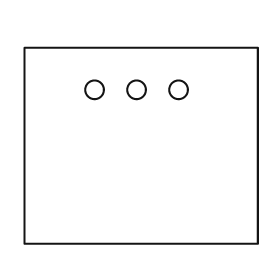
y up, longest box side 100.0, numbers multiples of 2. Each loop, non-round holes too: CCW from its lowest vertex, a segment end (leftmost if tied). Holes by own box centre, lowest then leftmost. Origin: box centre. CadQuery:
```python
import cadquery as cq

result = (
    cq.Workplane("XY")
    .moveTo(-50.0, -42.0)
    .lineTo(50.0, -42.0)
    .lineTo(50.0, 42.0)
    .lineTo(-50.0, 42.0)
    .close()
    .moveTo(-20.0, 24.0)
    .circle(4.0)
    .moveTo(-2.0, 24.0)
    .circle(4.0)
    .moveTo(16.0, 24.0)
    .circle(4.0)
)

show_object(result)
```